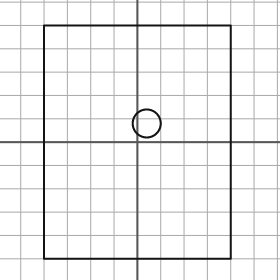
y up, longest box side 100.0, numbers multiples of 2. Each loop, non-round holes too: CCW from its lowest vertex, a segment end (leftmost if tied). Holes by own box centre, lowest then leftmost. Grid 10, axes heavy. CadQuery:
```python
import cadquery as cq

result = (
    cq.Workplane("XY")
    .moveTo(-40.0, -50.0)
    .lineTo(40.0, -50.0)
    .lineTo(40.0, 50.0)
    .lineTo(-40.0, 50.0)
    .close()
    .moveTo(4.0, 8.0)
    .circle(6.0)
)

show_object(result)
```